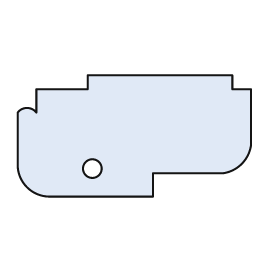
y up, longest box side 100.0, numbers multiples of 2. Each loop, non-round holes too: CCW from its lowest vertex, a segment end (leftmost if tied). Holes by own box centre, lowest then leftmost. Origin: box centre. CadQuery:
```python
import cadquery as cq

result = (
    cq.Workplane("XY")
    .moveTo(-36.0, -26.0)
    .lineTo(8.0, -26.0)
    .lineTo(8.0, -16.0)
    .lineTo(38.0, -16.0)
    .threePointArc((46.0, -12.0), (50.0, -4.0))
    .lineTo(50.0, 20.0)
    .lineTo(42.0, 20.0)
    .lineTo(42.0, 26.0)
    .lineTo(-20.0, 26.0)
    .lineTo(-20.0, 20.0)
    .lineTo(-42.0, 20.0)
    .lineTo(-42.0, 10.0)
    .threePointArc((-46.0, 12.0), (-50.0, 10.0))
    .lineTo(-50.0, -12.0)
    .threePointArc((-46.0, -22.0), (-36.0, -26.0))
    .close()
    .moveTo(-18.0, -14.0)
    .circle(4.0)
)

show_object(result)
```